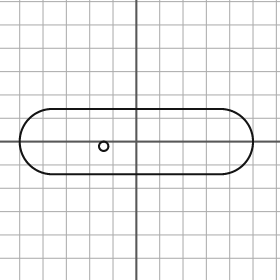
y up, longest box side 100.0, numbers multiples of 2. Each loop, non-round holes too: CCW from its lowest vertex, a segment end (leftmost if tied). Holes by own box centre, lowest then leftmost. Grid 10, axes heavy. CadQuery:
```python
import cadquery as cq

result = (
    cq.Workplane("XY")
    .moveTo(-36.0, -14.0)
    .lineTo(36.0, -14.0)
    .threePointArc((50.0, 0.0), (36.0, 14.0))
    .lineTo(-36.0, 14.0)
    .threePointArc((-50.0, 0.0), (-36.0, -14.0))
    .close()
    .moveTo(-14.0, -2.0)
    .circle(2.0)
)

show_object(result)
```